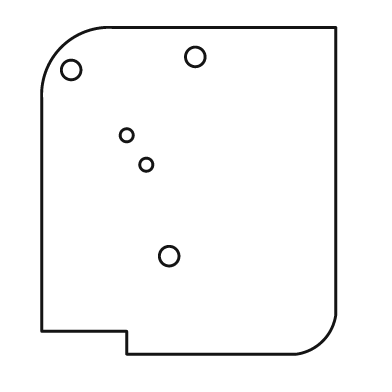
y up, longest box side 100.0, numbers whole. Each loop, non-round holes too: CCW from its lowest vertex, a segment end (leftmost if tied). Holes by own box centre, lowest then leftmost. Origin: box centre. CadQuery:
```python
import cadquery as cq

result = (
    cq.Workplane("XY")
    .moveTo(-19.0, -50.0)
    .lineTo(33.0, -50.0)
    .threePointArc((41.0, -46.0), (45.0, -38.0))
    .lineTo(45.0, 50.0)
    .lineTo(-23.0, 50.0)
    .threePointArc((-39.0, 44.0), (-45.0, 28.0))
    .lineTo(-45.0, -43.0)
    .lineTo(-19.0, -43.0)
    .close()
    .moveTo(-6.0, -20.0)
    .circle(3.0)
    .moveTo(-13.0, 8.0)
    .circle(2.0)
    .moveTo(-19.0, 17.0)
    .circle(2.0)
    .moveTo(-36.0, 37.0)
    .circle(3.0)
    .moveTo(2.0, 41.0)
    .circle(3.0)
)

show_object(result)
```